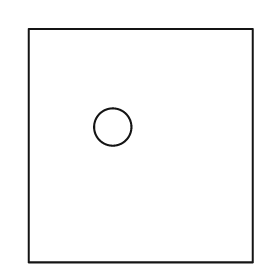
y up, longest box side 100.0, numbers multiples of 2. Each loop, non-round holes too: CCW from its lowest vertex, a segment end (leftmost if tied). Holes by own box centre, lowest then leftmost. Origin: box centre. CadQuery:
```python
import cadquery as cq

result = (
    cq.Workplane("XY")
    .moveTo(-48.0, -50.0)
    .lineTo(48.0, -50.0)
    .lineTo(48.0, 50.0)
    .lineTo(-48.0, 50.0)
    .close()
    .moveTo(-12.0, 8.0)
    .circle(8.0)
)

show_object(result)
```